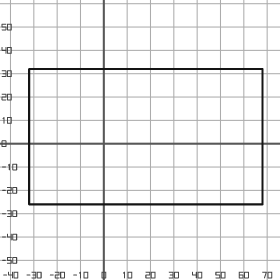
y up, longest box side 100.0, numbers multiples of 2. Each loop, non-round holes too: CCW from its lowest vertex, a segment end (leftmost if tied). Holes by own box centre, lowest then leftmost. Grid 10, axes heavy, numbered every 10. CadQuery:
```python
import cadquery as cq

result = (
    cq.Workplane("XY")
    .moveTo(-32.0, -26.0)
    .lineTo(68.0, -26.0)
    .lineTo(68.0, 32.0)
    .lineTo(-32.0, 32.0)
    .close()
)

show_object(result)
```